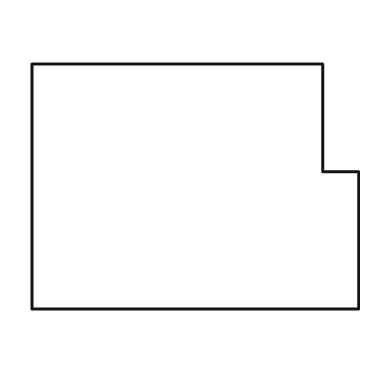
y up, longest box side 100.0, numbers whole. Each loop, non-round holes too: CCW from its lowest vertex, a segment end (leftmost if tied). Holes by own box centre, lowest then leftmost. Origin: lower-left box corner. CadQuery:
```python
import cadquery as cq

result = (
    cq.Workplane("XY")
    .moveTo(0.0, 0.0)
    .lineTo(100.0, 0.0)
    .lineTo(100.0, 42.0)
    .lineTo(89.0, 42.0)
    .lineTo(89.0, 75.0)
    .lineTo(0.0, 75.0)
    .close()
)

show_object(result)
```